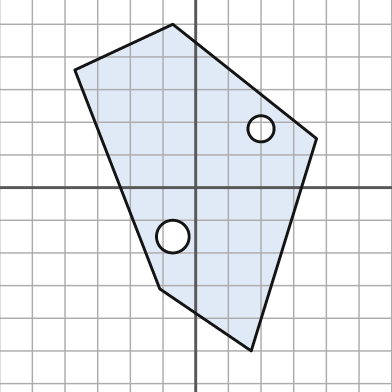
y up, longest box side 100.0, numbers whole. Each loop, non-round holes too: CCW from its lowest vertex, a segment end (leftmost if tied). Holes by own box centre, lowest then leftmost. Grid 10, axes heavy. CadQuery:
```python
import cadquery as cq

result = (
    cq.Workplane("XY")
    .moveTo(17.0, -50.0)
    .lineTo(37.0, 15.0)
    .lineTo(-7.0, 50.0)
    .lineTo(-37.0, 36.0)
    .lineTo(-11.0, -31.0)
    .close()
    .moveTo(-7.0, -15.0)
    .circle(5.0)
    .moveTo(20.0, 18.0)
    .circle(4.0)
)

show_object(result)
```